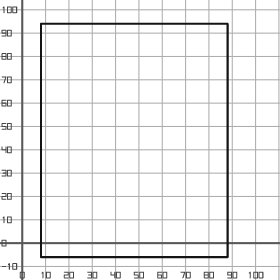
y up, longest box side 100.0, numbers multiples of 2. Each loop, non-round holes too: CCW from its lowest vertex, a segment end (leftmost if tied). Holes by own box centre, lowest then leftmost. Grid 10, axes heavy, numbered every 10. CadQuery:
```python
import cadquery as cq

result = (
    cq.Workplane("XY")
    .moveTo(8.0, -6.0)
    .lineTo(88.0, -6.0)
    .lineTo(88.0, 94.0)
    .lineTo(8.0, 94.0)
    .close()
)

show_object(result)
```